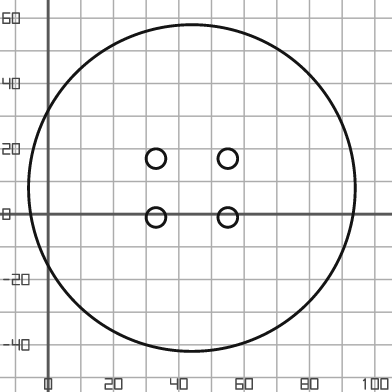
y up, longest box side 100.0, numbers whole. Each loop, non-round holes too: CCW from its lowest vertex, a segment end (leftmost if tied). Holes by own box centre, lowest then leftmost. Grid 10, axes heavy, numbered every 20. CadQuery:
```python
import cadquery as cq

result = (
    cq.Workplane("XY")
    .moveTo(44.0, 8.0)
    .circle(50.0)
    .moveTo(33.0, -1.0)
    .circle(3.0)
    .moveTo(55.0, -1.0)
    .circle(3.0)
    .moveTo(33.0, 17.0)
    .circle(3.0)
    .moveTo(55.0, 17.0)
    .circle(3.0)
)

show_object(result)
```